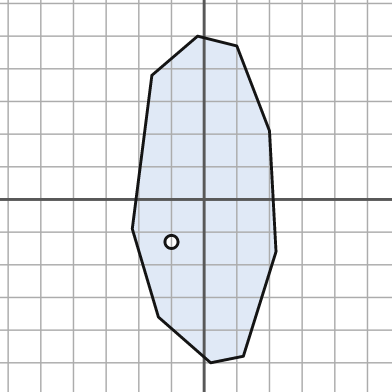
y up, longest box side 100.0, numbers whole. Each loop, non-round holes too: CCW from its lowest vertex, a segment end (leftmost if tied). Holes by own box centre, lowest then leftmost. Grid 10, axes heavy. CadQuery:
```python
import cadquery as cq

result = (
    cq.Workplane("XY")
    .moveTo(2.0, -50.0)
    .lineTo(12.0, -48.0)
    .lineTo(22.0, -16.0)
    .lineTo(20.0, 21.0)
    .lineTo(10.0, 47.0)
    .lineTo(-2.0, 50.0)
    .lineTo(-16.0, 38.0)
    .lineTo(-22.0, -9.0)
    .lineTo(-14.0, -36.0)
    .close()
    .moveTo(-10.0, -13.0)
    .circle(2.0)
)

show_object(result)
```